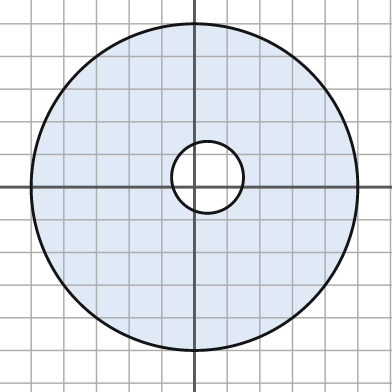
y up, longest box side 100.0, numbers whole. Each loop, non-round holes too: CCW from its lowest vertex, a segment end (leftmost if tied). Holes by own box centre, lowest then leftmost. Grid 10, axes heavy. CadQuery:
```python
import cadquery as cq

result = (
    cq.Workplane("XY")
    .moveTo(0.0, 0.0)
    .circle(50.0)
    .moveTo(4.0, 3.0)
    .circle(11.0)
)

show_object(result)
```